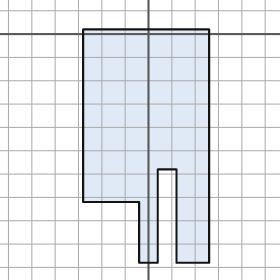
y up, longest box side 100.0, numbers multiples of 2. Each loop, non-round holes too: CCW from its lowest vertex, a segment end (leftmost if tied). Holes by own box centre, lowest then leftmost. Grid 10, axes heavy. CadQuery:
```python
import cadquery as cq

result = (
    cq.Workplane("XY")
    .moveTo(-4.0, -98.0)
    .lineTo(4.0, -98.0)
    .lineTo(4.0, -58.0)
    .lineTo(12.0, -58.0)
    .lineTo(12.0, -98.0)
    .lineTo(26.0, -98.0)
    .lineTo(26.0, 2.0)
    .lineTo(-28.0, 2.0)
    .lineTo(-28.0, -72.0)
    .lineTo(-4.0, -72.0)
    .close()
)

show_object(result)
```